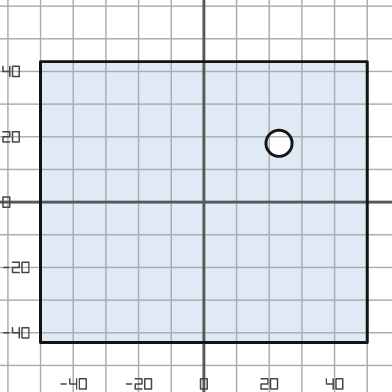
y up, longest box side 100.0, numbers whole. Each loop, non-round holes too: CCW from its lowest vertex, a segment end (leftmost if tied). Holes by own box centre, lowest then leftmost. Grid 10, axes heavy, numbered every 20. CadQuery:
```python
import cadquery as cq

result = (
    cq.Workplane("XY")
    .moveTo(-50.0, -43.0)
    .lineTo(50.0, -43.0)
    .lineTo(50.0, 43.0)
    .lineTo(-50.0, 43.0)
    .close()
    .moveTo(23.0, 18.0)
    .circle(4.0)
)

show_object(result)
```